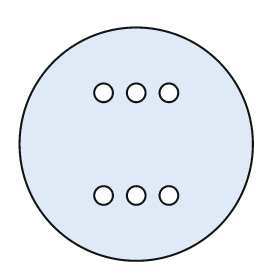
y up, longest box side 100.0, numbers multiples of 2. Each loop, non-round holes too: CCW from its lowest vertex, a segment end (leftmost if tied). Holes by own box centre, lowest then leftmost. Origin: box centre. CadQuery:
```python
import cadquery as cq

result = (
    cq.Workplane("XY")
    .moveTo(0.0, 0.0)
    .circle(50.0)
    .moveTo(-14.0, -22.0)
    .circle(4.0)
    .moveTo(0.0, -22.0)
    .circle(4.0)
    .moveTo(14.0, -22.0)
    .circle(4.0)
    .moveTo(-14.0, 22.0)
    .circle(4.0)
    .moveTo(0.0, 22.0)
    .circle(4.0)
    .moveTo(14.0, 22.0)
    .circle(4.0)
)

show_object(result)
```